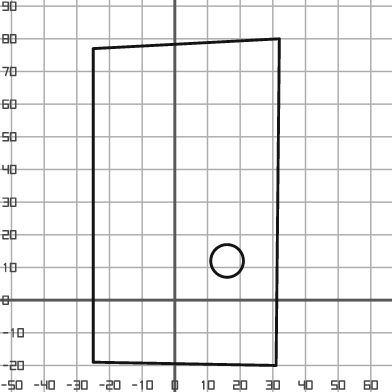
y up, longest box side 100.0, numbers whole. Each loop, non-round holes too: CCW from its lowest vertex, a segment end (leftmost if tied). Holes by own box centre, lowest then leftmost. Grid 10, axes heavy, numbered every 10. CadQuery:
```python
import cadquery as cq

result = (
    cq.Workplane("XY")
    .moveTo(31.0, -20.0)
    .lineTo(32.0, 80.0)
    .lineTo(-25.0, 77.0)
    .lineTo(-25.0, -19.0)
    .close()
    .moveTo(16.0, 12.0)
    .circle(5.0)
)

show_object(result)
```